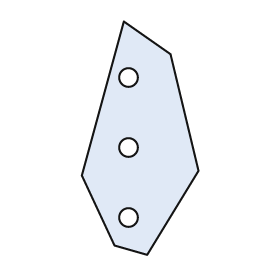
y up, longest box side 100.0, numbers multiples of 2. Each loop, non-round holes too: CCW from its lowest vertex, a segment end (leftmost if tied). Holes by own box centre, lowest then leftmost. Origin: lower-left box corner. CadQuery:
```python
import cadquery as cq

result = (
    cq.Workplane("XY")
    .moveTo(28.0, 0.0)
    .lineTo(50.0, 36.0)
    .lineTo(38.0, 86.0)
    .lineTo(18.0, 100.0)
    .lineTo(0.0, 34.0)
    .lineTo(14.0, 4.0)
    .close()
    .moveTo(20.0, 16.0)
    .circle(4.0)
    .moveTo(20.0, 46.0)
    .circle(4.0)
    .moveTo(20.0, 76.0)
    .circle(4.0)
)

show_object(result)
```